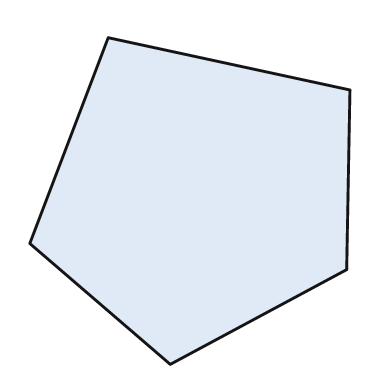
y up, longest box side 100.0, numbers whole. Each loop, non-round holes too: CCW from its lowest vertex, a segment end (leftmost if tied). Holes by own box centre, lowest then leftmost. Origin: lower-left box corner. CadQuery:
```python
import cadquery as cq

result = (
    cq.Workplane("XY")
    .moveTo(43.0, 0.0)
    .lineTo(97.0, 29.0)
    .lineTo(98.0, 84.0)
    .lineTo(24.0, 100.0)
    .lineTo(0.0, 37.0)
    .close()
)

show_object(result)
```